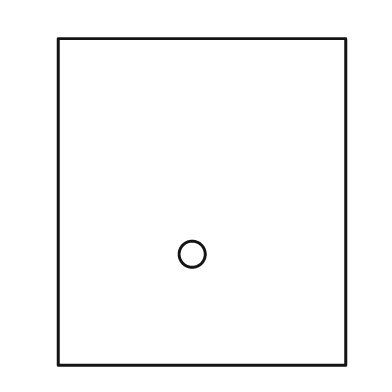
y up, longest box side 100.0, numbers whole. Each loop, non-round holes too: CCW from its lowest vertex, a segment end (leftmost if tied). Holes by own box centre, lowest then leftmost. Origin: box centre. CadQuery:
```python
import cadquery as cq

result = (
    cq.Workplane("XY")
    .moveTo(-44.0, -50.0)
    .lineTo(44.0, -50.0)
    .lineTo(44.0, 50.0)
    .lineTo(-44.0, 50.0)
    .close()
    .moveTo(-3.0, -16.0)
    .circle(4.0)
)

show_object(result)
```